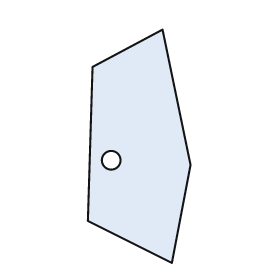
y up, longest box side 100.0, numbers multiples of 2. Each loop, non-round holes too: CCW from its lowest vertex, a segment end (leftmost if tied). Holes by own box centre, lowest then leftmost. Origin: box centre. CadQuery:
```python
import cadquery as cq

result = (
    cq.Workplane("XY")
    .moveTo(14.0, -50.0)
    .lineTo(22.0, -8.0)
    .lineTo(10.0, 50.0)
    .lineTo(-20.0, 34.0)
    .lineTo(-22.0, -32.0)
    .close()
    .moveTo(-12.0, -6.0)
    .circle(4.0)
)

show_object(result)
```